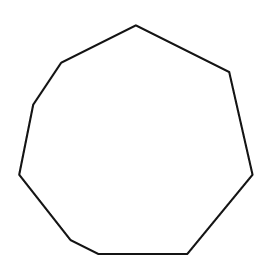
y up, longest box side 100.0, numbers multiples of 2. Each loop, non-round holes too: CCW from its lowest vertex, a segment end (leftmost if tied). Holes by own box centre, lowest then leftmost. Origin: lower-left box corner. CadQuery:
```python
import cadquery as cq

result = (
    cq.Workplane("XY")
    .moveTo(34.0, 0.0)
    .lineTo(72.0, 0.0)
    .lineTo(100.0, 34.0)
    .lineTo(90.0, 78.0)
    .lineTo(50.0, 98.0)
    .lineTo(18.0, 82.0)
    .lineTo(6.0, 64.0)
    .lineTo(0.0, 34.0)
    .lineTo(22.0, 6.0)
    .close()
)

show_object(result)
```